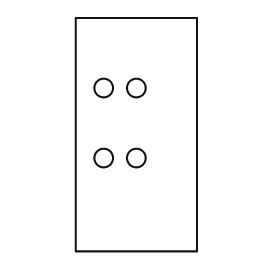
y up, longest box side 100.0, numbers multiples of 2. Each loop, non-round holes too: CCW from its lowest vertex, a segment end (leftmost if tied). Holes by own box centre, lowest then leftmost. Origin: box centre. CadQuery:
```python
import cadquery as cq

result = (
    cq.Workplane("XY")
    .moveTo(-26.0, -50.0)
    .lineTo(26.0, -50.0)
    .lineTo(26.0, 50.0)
    .lineTo(-26.0, 50.0)
    .close()
    .moveTo(-14.0, -10.0)
    .circle(4.0)
    .moveTo(0.0, -10.0)
    .circle(4.0)
    .moveTo(-14.0, 20.0)
    .circle(4.0)
    .moveTo(0.0, 20.0)
    .circle(4.0)
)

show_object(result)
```